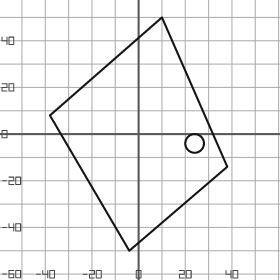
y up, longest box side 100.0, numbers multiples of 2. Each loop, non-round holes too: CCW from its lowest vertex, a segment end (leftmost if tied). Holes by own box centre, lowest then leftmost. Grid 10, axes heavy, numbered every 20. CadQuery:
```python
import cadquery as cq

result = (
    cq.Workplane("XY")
    .moveTo(-4.0, -50.0)
    .lineTo(38.0, -14.0)
    .lineTo(10.0, 50.0)
    .lineTo(-38.0, 8.0)
    .close()
    .moveTo(24.0, -4.0)
    .circle(4.0)
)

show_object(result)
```